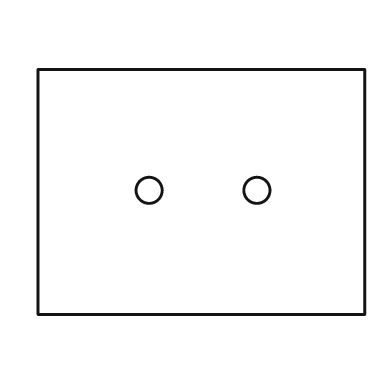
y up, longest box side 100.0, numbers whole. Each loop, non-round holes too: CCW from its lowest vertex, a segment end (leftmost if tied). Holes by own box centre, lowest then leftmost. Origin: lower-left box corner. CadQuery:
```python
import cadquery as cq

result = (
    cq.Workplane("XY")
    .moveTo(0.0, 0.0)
    .lineTo(100.0, 0.0)
    .lineTo(100.0, 75.0)
    .lineTo(0.0, 75.0)
    .close()
    .moveTo(34.0, 38.0)
    .circle(4.0)
    .moveTo(67.0, 38.0)
    .circle(4.0)
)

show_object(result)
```